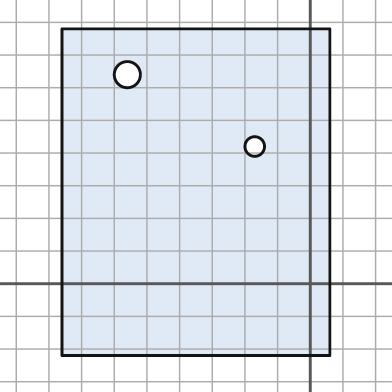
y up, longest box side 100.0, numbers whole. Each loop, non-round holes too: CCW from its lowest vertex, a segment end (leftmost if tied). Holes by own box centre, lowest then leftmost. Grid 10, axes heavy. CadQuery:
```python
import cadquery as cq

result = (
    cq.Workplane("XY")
    .moveTo(-76.0, -22.0)
    .lineTo(6.0, -22.0)
    .lineTo(6.0, 78.0)
    .lineTo(-76.0, 78.0)
    .close()
    .moveTo(-17.0, 42.0)
    .circle(3.0)
    .moveTo(-56.0, 64.0)
    .circle(4.0)
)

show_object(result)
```